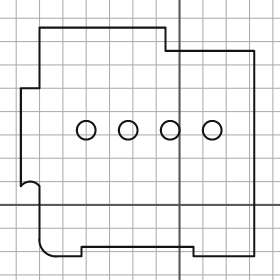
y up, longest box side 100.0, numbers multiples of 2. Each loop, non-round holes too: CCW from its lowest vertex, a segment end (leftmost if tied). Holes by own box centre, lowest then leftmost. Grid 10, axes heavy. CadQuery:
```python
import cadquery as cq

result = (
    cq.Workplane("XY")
    .moveTo(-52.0, -22.0)
    .lineTo(-42.0, -22.0)
    .lineTo(-42.0, -18.0)
    .lineTo(6.0, -18.0)
    .lineTo(6.0, -22.0)
    .lineTo(32.0, -22.0)
    .lineTo(32.0, 66.0)
    .lineTo(-6.0, 66.0)
    .lineTo(-6.0, 76.0)
    .lineTo(-60.0, 76.0)
    .lineTo(-60.0, 50.0)
    .lineTo(-68.0, 50.0)
    .lineTo(-68.0, 8.0)
    .threePointArc((-64.0, 10.0), (-60.0, 8.0))
    .lineTo(-60.0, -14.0)
    .threePointArc((-58.0, -20.0), (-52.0, -22.0))
    .close()
    .moveTo(-40.0, 32.0)
    .circle(4.0)
    .moveTo(-22.0, 32.0)
    .circle(4.0)
    .moveTo(-4.0, 32.0)
    .circle(4.0)
    .moveTo(14.0, 32.0)
    .circle(4.0)
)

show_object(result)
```